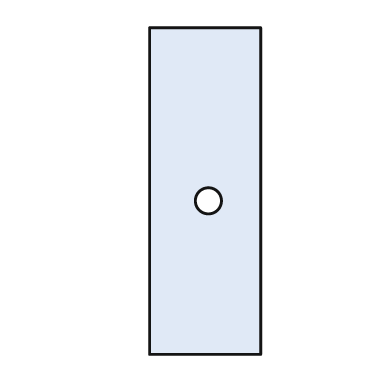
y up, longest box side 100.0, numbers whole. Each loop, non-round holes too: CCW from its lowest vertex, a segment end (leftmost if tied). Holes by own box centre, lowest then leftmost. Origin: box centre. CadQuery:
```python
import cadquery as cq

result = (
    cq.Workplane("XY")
    .moveTo(-17.0, -50.0)
    .lineTo(17.0, -50.0)
    .lineTo(17.0, 50.0)
    .lineTo(-17.0, 50.0)
    .close()
    .moveTo(1.0, -3.0)
    .circle(4.0)
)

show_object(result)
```